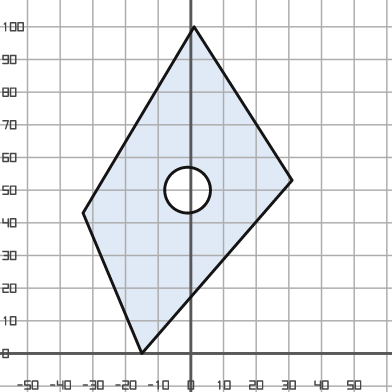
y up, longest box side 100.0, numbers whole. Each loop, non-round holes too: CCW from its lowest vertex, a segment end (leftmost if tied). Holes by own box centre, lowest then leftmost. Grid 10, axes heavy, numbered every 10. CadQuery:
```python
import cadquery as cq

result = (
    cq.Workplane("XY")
    .moveTo(-15.0, 0.0)
    .lineTo(31.0, 53.0)
    .lineTo(1.0, 100.0)
    .lineTo(-33.0, 43.0)
    .close()
    .moveTo(-1.0, 50.0)
    .circle(7.0)
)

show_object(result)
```